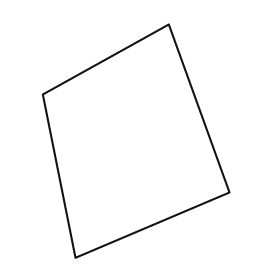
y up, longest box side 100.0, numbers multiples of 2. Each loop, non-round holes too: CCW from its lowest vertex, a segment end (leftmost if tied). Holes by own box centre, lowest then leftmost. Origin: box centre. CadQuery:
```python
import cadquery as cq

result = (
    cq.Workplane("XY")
    .moveTo(-26.0, -50.0)
    .lineTo(40.0, -22.0)
    .lineTo(14.0, 50.0)
    .lineTo(-40.0, 20.0)
    .close()
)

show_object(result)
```